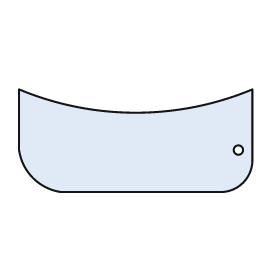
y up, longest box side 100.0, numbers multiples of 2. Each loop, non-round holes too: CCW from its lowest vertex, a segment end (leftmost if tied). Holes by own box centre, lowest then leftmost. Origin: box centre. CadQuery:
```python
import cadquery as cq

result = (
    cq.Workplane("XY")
    .moveTo(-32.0, -22.0)
    .lineTo(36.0, -22.0)
    .threePointArc((46.0, -18.0), (50.0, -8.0))
    .lineTo(50.0, 22.0)
    .threePointArc((0.0, 12.0), (-50.0, 22.0))
    .lineTo(-50.0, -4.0)
    .threePointArc((-44.0, -16.0), (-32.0, -22.0))
    .close()
    .moveTo(44.0, -4.0)
    .circle(2.0)
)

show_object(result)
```